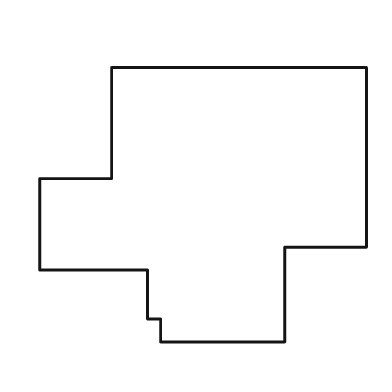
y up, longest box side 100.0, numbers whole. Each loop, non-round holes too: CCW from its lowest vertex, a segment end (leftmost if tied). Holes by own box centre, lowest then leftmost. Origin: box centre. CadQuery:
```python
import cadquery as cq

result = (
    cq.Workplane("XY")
    .moveTo(-13.0, -42.0)
    .lineTo(25.0, -42.0)
    .lineTo(25.0, -13.0)
    .lineTo(50.0, -13.0)
    .lineTo(50.0, 42.0)
    .lineTo(-28.0, 42.0)
    .lineTo(-28.0, 8.0)
    .lineTo(-50.0, 8.0)
    .lineTo(-50.0, -20.0)
    .lineTo(-17.0, -20.0)
    .lineTo(-17.0, -35.0)
    .lineTo(-13.0, -35.0)
    .close()
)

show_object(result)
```